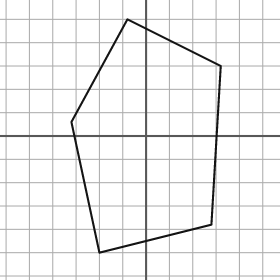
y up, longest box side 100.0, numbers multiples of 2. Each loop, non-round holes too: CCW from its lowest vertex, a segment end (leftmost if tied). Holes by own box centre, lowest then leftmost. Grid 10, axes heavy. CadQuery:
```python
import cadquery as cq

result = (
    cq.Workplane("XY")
    .moveTo(-20.0, -50.0)
    .lineTo(28.0, -38.0)
    .lineTo(32.0, 30.0)
    .lineTo(-8.0, 50.0)
    .lineTo(-32.0, 6.0)
    .close()
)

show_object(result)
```